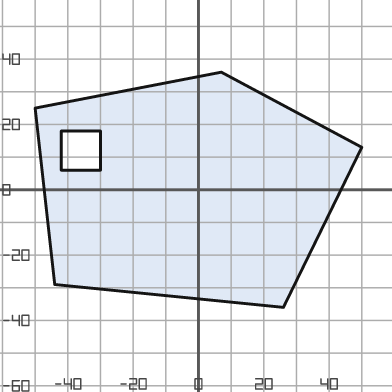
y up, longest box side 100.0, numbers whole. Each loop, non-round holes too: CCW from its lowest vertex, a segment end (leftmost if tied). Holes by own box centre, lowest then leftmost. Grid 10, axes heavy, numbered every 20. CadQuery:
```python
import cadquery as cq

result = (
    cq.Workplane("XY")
    .moveTo(26.0, -36.0)
    .lineTo(50.0, 13.0)
    .lineTo(7.0, 36.0)
    .lineTo(-50.0, 25.0)
    .lineTo(-44.0, -29.0)
    .close()
    .moveTo(-42.0, 6.0)
    .lineTo(-30.0, 6.0)
    .lineTo(-30.0, 18.0)
    .lineTo(-42.0, 18.0)
    .close()
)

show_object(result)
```